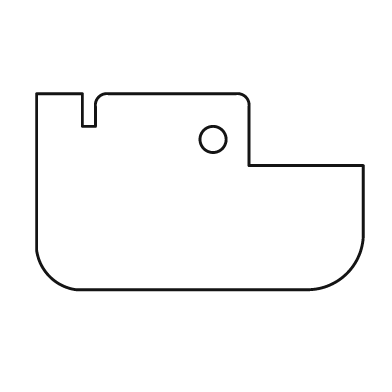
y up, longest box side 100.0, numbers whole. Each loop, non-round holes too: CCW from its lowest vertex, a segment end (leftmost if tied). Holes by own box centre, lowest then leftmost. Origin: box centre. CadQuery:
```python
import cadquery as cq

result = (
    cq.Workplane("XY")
    .moveTo(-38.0, -30.0)
    .lineTo(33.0, -30.0)
    .threePointArc((45.0, -25.0), (50.0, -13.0))
    .lineTo(50.0, 8.0)
    .lineTo(15.0, 8.0)
    .lineTo(15.0, 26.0)
    .threePointArc((14.0, 29.0), (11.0, 30.0))
    .lineTo(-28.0, 30.0)
    .threePointArc((-31.0, 29.0), (-32.0, 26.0))
    .lineTo(-32.0, 20.0)
    .lineTo(-36.0, 20.0)
    .lineTo(-36.0, 30.0)
    .lineTo(-50.0, 30.0)
    .lineTo(-50.0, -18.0)
    .threePointArc((-46.0, -26.0), (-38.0, -30.0))
    .close()
    .moveTo(4.0, 16.0)
    .circle(4.0)
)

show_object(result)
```